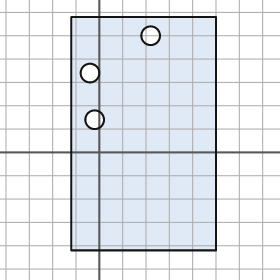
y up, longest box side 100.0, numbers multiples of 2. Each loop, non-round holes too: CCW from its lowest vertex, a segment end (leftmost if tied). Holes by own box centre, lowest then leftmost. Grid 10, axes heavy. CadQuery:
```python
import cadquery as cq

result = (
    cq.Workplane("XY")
    .moveTo(-12.0, -42.0)
    .lineTo(50.0, -42.0)
    .lineTo(50.0, 58.0)
    .lineTo(-12.0, 58.0)
    .close()
    .moveTo(-2.0, 14.0)
    .circle(4.0)
    .moveTo(-4.0, 34.0)
    .circle(4.0)
    .moveTo(22.0, 50.0)
    .circle(4.0)
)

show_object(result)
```